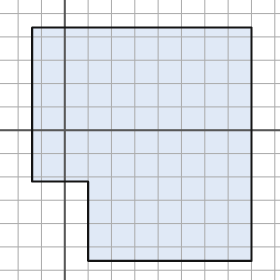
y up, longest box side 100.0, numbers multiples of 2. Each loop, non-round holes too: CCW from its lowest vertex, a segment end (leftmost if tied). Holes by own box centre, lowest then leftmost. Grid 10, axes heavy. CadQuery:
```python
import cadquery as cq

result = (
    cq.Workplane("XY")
    .moveTo(10.0, -56.0)
    .lineTo(80.0, -56.0)
    .lineTo(80.0, 44.0)
    .lineTo(-14.0, 44.0)
    .lineTo(-14.0, -22.0)
    .lineTo(10.0, -22.0)
    .close()
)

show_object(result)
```